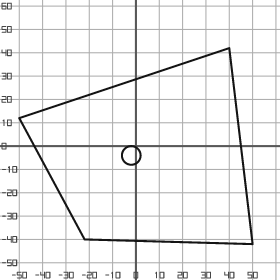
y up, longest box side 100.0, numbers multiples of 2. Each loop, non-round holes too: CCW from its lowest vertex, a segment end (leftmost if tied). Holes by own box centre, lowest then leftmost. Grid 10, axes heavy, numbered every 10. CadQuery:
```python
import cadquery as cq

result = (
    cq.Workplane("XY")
    .moveTo(50.0, -42.0)
    .lineTo(40.0, 42.0)
    .lineTo(-50.0, 12.0)
    .lineTo(-22.0, -40.0)
    .close()
    .moveTo(-2.0, -4.0)
    .circle(4.0)
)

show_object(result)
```